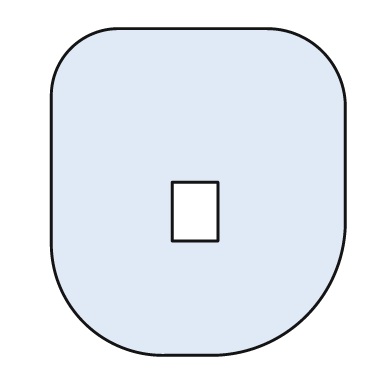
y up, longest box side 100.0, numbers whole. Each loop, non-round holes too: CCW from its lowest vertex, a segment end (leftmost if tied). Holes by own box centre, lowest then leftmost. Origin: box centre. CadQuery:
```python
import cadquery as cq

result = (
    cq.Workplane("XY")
    .moveTo(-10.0, -50.0)
    .lineTo(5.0, -50.0)
    .threePointArc((33.0, -38.0), (45.0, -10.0))
    .lineTo(45.0, 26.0)
    .threePointArc((38.0, 43.0), (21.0, 50.0))
    .lineTo(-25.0, 50.0)
    .threePointArc((-39.0, 44.0), (-45.0, 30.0))
    .lineTo(-45.0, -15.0)
    .threePointArc((-35.0, -40.0), (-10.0, -50.0))
    .close()
    .moveTo(-8.0, -15.0)
    .lineTo(6.0, -15.0)
    .lineTo(6.0, 3.0)
    .lineTo(-8.0, 3.0)
    .close()
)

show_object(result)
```